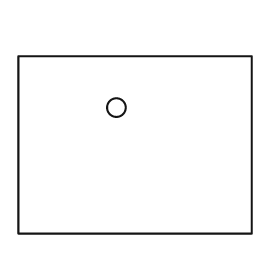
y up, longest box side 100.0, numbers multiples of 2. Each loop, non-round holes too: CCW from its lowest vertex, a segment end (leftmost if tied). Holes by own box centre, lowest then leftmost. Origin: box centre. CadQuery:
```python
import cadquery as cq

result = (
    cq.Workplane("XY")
    .moveTo(-50.0, -38.0)
    .lineTo(50.0, -38.0)
    .lineTo(50.0, 38.0)
    .lineTo(-50.0, 38.0)
    .close()
    .moveTo(-8.0, 16.0)
    .circle(4.0)
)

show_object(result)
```